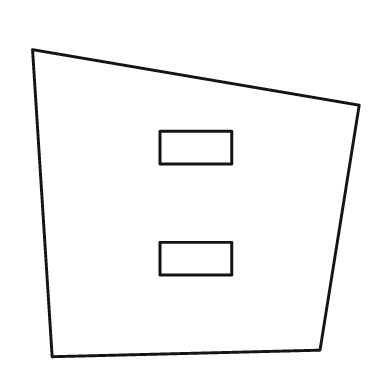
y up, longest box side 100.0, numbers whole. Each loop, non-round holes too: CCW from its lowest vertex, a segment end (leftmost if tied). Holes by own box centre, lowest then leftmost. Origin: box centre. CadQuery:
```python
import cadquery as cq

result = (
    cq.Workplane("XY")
    .moveTo(-44.0, -47.0)
    .lineTo(38.0, -45.0)
    .lineTo(50.0, 30.0)
    .lineTo(-50.0, 47.0)
    .close()
    .moveTo(-11.0, -22.0)
    .lineTo(11.0, -22.0)
    .lineTo(11.0, -12.0)
    .lineTo(-11.0, -12.0)
    .close()
    .moveTo(-11.0, 12.0)
    .lineTo(11.0, 12.0)
    .lineTo(11.0, 22.0)
    .lineTo(-11.0, 22.0)
    .close()
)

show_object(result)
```